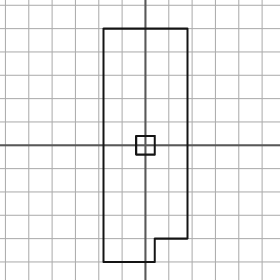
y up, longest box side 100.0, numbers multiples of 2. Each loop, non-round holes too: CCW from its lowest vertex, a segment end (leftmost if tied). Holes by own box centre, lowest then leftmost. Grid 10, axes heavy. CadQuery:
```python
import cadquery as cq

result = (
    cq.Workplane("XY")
    .moveTo(-18.0, -50.0)
    .lineTo(4.0, -50.0)
    .lineTo(4.0, -40.0)
    .lineTo(18.0, -40.0)
    .lineTo(18.0, 50.0)
    .lineTo(-18.0, 50.0)
    .close()
    .moveTo(-4.0, -4.0)
    .lineTo(4.0, -4.0)
    .lineTo(4.0, 4.0)
    .lineTo(-4.0, 4.0)
    .close()
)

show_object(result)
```